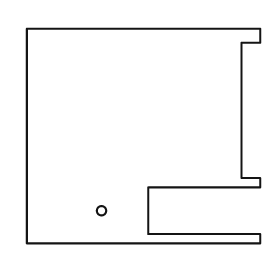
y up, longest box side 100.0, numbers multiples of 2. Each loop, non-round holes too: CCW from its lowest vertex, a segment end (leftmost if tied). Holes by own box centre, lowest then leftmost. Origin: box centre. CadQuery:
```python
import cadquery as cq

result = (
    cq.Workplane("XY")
    .moveTo(-50.0, -46.0)
    .lineTo(50.0, -46.0)
    .lineTo(50.0, -42.0)
    .lineTo(2.0, -42.0)
    .lineTo(2.0, -22.0)
    .lineTo(50.0, -22.0)
    .lineTo(50.0, -18.0)
    .lineTo(42.0, -18.0)
    .lineTo(42.0, 40.0)
    .lineTo(50.0, 40.0)
    .lineTo(50.0, 46.0)
    .lineTo(-50.0, 46.0)
    .close()
    .moveTo(-18.0, -32.0)
    .circle(2.0)
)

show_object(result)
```